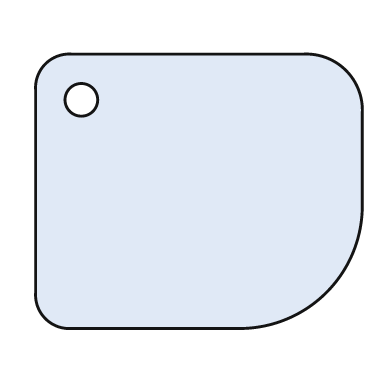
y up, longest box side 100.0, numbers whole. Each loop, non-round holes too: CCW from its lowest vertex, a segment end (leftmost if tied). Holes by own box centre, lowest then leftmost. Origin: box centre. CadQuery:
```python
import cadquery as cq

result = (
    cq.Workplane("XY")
    .moveTo(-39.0, -42.0)
    .lineTo(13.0, -42.0)
    .threePointArc((39.0, -31.0), (50.0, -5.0))
    .lineTo(50.0, 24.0)
    .threePointArc((45.0, 37.0), (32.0, 42.0))
    .lineTo(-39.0, 42.0)
    .threePointArc((-47.0, 39.0), (-50.0, 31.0))
    .lineTo(-50.0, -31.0)
    .threePointArc((-47.0, -39.0), (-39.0, -42.0))
    .close()
    .moveTo(-36.0, 28.0)
    .circle(5.0)
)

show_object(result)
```